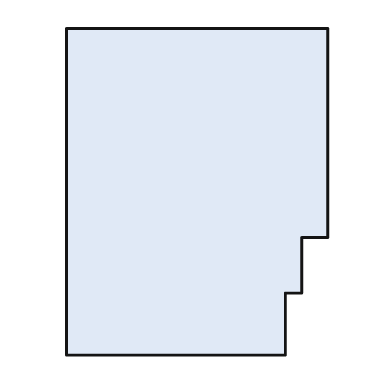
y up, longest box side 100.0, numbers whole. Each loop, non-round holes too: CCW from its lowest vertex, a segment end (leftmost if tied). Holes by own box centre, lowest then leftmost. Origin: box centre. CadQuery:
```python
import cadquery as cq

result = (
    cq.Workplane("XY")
    .moveTo(-40.0, -50.0)
    .lineTo(27.0, -50.0)
    .lineTo(27.0, -31.0)
    .lineTo(32.0, -31.0)
    .lineTo(32.0, -14.0)
    .lineTo(40.0, -14.0)
    .lineTo(40.0, 50.0)
    .lineTo(-40.0, 50.0)
    .close()
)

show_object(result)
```